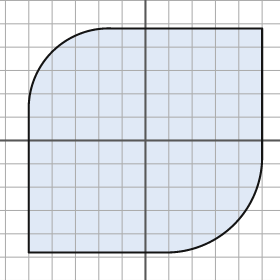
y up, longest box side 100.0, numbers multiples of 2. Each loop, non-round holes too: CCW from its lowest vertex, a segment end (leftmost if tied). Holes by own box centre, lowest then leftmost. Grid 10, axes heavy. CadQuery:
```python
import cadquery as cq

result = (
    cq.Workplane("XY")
    .moveTo(-50.0, -48.0)
    .lineTo(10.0, -48.0)
    .threePointArc((38.0, -36.0), (50.0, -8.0))
    .lineTo(50.0, 48.0)
    .lineTo(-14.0, 48.0)
    .threePointArc((-40.0, 38.0), (-50.0, 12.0))
    .close()
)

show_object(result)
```